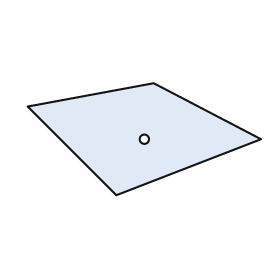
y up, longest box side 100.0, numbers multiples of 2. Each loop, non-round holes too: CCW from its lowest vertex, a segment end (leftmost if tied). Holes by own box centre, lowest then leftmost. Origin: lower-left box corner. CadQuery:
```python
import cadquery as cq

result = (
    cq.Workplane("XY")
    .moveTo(38.0, 0.0)
    .lineTo(100.0, 24.0)
    .lineTo(54.0, 48.0)
    .lineTo(0.0, 38.0)
    .close()
    .moveTo(50.0, 24.0)
    .circle(2.0)
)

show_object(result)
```